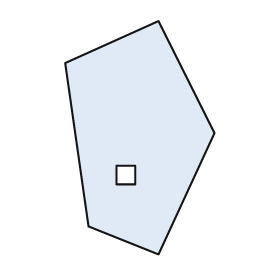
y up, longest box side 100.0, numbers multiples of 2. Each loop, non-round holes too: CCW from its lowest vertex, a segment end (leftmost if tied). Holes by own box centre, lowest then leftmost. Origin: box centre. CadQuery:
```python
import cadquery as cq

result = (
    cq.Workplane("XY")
    .moveTo(8.0, -50.0)
    .lineTo(32.0, 2.0)
    .lineTo(8.0, 50.0)
    .lineTo(-32.0, 32.0)
    .lineTo(-22.0, -38.0)
    .close()
    .moveTo(-10.0, -20.0)
    .lineTo(-2.0, -20.0)
    .lineTo(-2.0, -12.0)
    .lineTo(-10.0, -12.0)
    .close()
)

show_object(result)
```